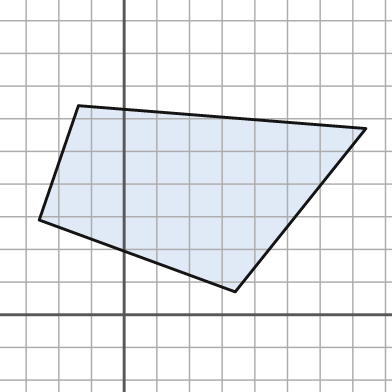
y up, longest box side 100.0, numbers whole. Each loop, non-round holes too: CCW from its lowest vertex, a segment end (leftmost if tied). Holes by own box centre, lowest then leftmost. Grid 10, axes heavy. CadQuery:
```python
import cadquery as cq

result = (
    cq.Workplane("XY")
    .moveTo(34.0, 7.0)
    .lineTo(74.0, 57.0)
    .lineTo(-14.0, 64.0)
    .lineTo(-26.0, 29.0)
    .close()
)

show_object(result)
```